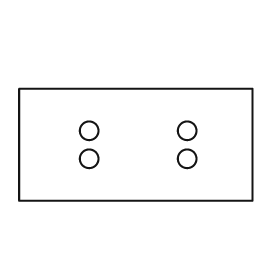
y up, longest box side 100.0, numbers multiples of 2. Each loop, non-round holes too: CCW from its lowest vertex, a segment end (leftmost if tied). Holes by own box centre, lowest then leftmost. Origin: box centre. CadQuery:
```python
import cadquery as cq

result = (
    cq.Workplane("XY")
    .moveTo(-50.0, -24.0)
    .lineTo(50.0, -24.0)
    .lineTo(50.0, 24.0)
    .lineTo(-50.0, 24.0)
    .close()
    .moveTo(-20.0, -6.0)
    .circle(4.0)
    .moveTo(22.0, -6.0)
    .circle(4.0)
    .moveTo(-20.0, 6.0)
    .circle(4.0)
    .moveTo(22.0, 6.0)
    .circle(4.0)
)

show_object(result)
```